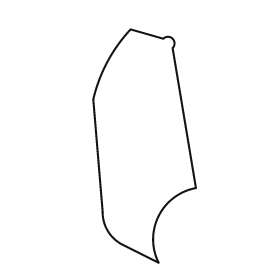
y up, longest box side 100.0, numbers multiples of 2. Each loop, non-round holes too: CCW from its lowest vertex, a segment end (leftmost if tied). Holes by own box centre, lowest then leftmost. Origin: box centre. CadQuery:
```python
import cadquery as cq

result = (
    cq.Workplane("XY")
    .moveTo(6.0, -50.0)
    .threePointArc((6.0, -30.0), (22.0, -18.0))
    .lineTo(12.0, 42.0)
    .threePointArc((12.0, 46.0), (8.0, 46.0))
    .lineTo(-6.0, 50.0)
    .threePointArc((-16.0, 36.0), (-22.0, 20.0))
    .lineTo(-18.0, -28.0)
    .threePointArc((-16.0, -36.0), (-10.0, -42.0))
    .close()
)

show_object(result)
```